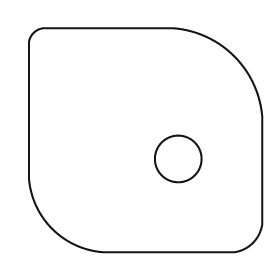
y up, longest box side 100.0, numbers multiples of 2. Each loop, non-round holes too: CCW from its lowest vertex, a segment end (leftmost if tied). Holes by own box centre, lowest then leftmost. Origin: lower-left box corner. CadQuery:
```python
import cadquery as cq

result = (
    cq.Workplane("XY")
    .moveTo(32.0, 0.0)
    .lineTo(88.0, 0.0)
    .threePointArc((96.0, 4.0), (100.0, 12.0))
    .lineTo(100.0, 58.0)
    .threePointArc((88.0, 84.0), (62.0, 96.0))
    .lineTo(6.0, 96.0)
    .threePointArc((2.0, 94.0), (0.0, 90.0))
    .lineTo(0.0, 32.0)
    .threePointArc((10.0, 10.0), (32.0, 0.0))
    .close()
    .moveTo(64.0, 40.0)
    .circle(10.0)
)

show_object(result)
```